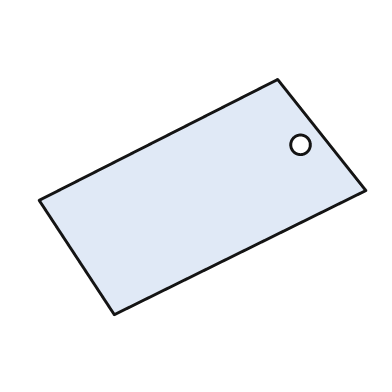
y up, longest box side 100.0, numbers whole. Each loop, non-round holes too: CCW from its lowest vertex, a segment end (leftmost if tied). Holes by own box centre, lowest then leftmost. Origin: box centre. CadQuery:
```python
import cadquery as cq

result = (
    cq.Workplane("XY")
    .moveTo(-27.0, -36.0)
    .lineTo(50.0, 2.0)
    .lineTo(23.0, 36.0)
    .lineTo(-50.0, -1.0)
    .close()
    .moveTo(30.0, 16.0)
    .circle(3.0)
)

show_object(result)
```